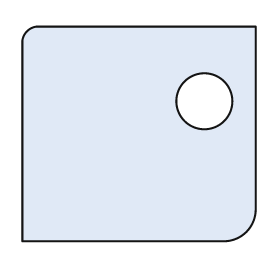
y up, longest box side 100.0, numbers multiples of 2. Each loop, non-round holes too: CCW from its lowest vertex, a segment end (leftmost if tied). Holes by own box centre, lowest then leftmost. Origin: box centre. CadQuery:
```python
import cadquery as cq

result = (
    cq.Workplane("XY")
    .moveTo(-50.0, -46.0)
    .lineTo(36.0, -46.0)
    .threePointArc((46.0, -42.0), (50.0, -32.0))
    .lineTo(50.0, 46.0)
    .lineTo(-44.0, 46.0)
    .threePointArc((-48.0, 44.0), (-50.0, 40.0))
    .close()
    .moveTo(28.0, 14.0)
    .circle(12.0)
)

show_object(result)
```